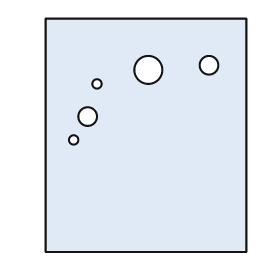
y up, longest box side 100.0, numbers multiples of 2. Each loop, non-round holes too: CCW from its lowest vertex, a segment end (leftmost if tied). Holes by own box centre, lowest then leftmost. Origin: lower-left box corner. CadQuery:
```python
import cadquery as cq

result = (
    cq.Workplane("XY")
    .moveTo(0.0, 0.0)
    .lineTo(86.0, 0.0)
    .lineTo(86.0, 100.0)
    .lineTo(0.0, 100.0)
    .close()
    .moveTo(12.0, 48.0)
    .circle(2.0)
    .moveTo(18.0, 58.0)
    .circle(4.0)
    .moveTo(22.0, 72.0)
    .circle(2.0)
    .moveTo(44.0, 78.0)
    .circle(6.0)
    .moveTo(70.0, 80.0)
    .circle(4.0)
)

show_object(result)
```